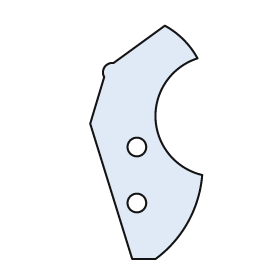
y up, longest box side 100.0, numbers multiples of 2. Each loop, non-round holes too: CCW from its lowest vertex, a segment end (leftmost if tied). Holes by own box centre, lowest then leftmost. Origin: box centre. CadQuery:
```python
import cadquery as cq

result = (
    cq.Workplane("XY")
    .moveTo(-6.0, -50.0)
    .lineTo(4.0, -50.0)
    .threePointArc((18.0, -34.0), (24.0, -14.0))
    .threePointArc((4.0, 10.0), (22.0, 36.0))
    .threePointArc((16.0, 44.0), (8.0, 50.0))
    .lineTo(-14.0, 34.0)
    .threePointArc((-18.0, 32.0), (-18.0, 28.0))
    .lineTo(-24.0, 8.0)
    .close()
    .moveTo(-4.0, -26.0)
    .circle(4.0)
    .moveTo(-4.0, -2.0)
    .circle(4.0)
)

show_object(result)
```